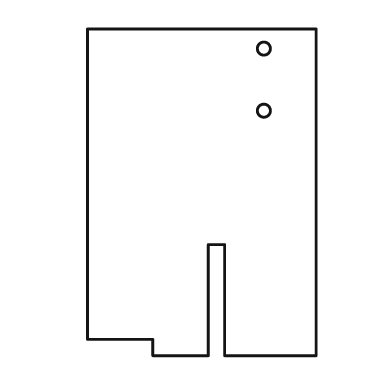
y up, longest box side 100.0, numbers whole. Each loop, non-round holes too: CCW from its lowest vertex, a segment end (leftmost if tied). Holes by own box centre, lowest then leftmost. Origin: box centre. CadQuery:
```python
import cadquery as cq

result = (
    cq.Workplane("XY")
    .moveTo(-15.0, -50.0)
    .lineTo(2.0, -50.0)
    .lineTo(2.0, -16.0)
    .lineTo(7.0, -16.0)
    .lineTo(7.0, -50.0)
    .lineTo(35.0, -50.0)
    .lineTo(35.0, 50.0)
    .lineTo(-35.0, 50.0)
    .lineTo(-35.0, -45.0)
    .lineTo(-15.0, -45.0)
    .close()
    .moveTo(19.0, 25.0)
    .circle(2.0)
    .moveTo(19.0, 44.0)
    .circle(2.0)
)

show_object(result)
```